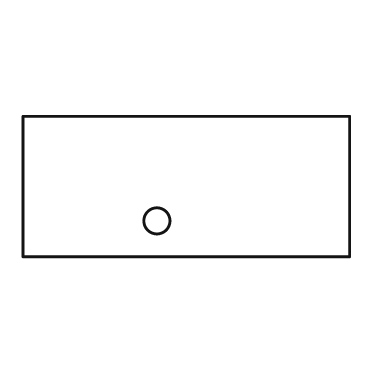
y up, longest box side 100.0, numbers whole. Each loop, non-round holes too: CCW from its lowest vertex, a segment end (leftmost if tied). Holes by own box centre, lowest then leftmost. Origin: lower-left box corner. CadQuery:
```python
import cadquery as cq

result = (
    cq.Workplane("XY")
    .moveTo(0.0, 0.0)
    .lineTo(100.0, 0.0)
    .lineTo(100.0, 43.0)
    .lineTo(0.0, 43.0)
    .close()
    .moveTo(41.0, 11.0)
    .circle(4.0)
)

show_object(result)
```